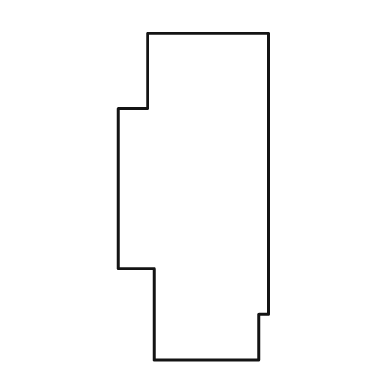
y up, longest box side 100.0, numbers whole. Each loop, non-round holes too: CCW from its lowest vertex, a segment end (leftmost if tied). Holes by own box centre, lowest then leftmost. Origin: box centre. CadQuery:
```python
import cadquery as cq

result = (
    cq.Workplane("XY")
    .moveTo(-12.0, -50.0)
    .lineTo(20.0, -50.0)
    .lineTo(20.0, -36.0)
    .lineTo(23.0, -36.0)
    .lineTo(23.0, 50.0)
    .lineTo(-14.0, 50.0)
    .lineTo(-14.0, 27.0)
    .lineTo(-23.0, 27.0)
    .lineTo(-23.0, -22.0)
    .lineTo(-12.0, -22.0)
    .close()
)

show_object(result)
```